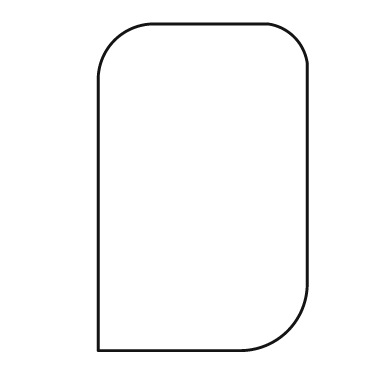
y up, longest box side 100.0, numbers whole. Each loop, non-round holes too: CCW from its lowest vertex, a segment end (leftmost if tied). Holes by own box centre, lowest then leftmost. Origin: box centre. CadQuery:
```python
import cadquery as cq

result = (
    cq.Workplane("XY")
    .moveTo(-32.0, -50.0)
    .lineTo(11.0, -50.0)
    .threePointArc((26.0, -44.0), (32.0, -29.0))
    .lineTo(32.0, 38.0)
    .threePointArc((28.0, 46.0), (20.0, 50.0))
    .lineTo(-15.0, 50.0)
    .threePointArc((-27.0, 45.0), (-32.0, 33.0))
    .close()
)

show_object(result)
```